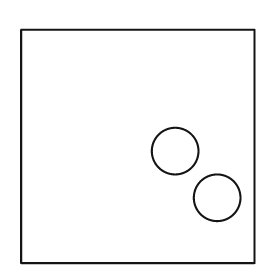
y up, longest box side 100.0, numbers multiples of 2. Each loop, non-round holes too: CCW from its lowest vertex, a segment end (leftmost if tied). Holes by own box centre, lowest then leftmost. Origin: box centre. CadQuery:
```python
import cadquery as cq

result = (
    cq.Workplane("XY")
    .moveTo(-50.0, -50.0)
    .lineTo(50.0, -50.0)
    .lineTo(50.0, 50.0)
    .lineTo(-50.0, 50.0)
    .close()
    .moveTo(34.0, -22.0)
    .circle(10.0)
    .moveTo(16.0, -2.0)
    .circle(10.0)
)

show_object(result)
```